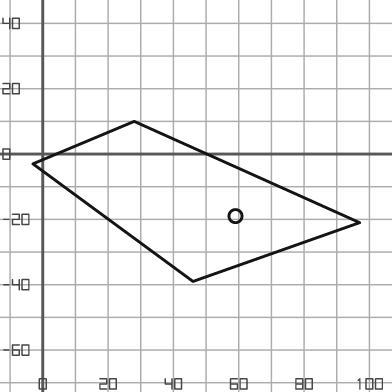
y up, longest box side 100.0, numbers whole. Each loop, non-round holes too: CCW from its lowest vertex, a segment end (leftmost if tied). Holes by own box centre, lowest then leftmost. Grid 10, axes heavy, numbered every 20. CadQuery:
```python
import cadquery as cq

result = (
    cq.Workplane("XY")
    .moveTo(46.0, -39.0)
    .lineTo(97.0, -21.0)
    .lineTo(28.0, 10.0)
    .lineTo(-3.0, -3.0)
    .close()
    .moveTo(59.0, -19.0)
    .circle(2.0)
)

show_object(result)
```